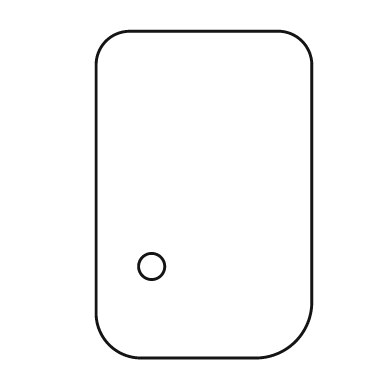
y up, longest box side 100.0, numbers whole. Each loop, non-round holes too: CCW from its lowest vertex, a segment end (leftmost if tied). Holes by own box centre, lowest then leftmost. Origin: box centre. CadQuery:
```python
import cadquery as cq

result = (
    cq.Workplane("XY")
    .moveTo(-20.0, -50.0)
    .lineTo(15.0, -50.0)
    .threePointArc((28.0, -45.0), (33.0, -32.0))
    .lineTo(33.0, 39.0)
    .threePointArc((30.0, 47.0), (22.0, 50.0))
    .lineTo(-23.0, 50.0)
    .threePointArc((-30.0, 47.0), (-33.0, 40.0))
    .lineTo(-33.0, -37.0)
    .threePointArc((-29.0, -46.0), (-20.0, -50.0))
    .close()
    .moveTo(-16.0, -22.0)
    .circle(4.0)
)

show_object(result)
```